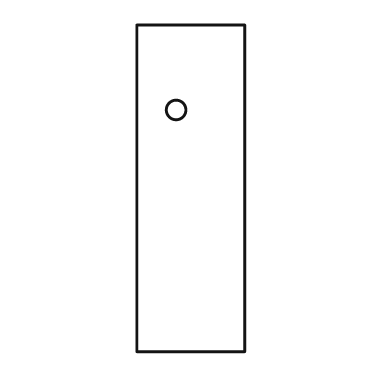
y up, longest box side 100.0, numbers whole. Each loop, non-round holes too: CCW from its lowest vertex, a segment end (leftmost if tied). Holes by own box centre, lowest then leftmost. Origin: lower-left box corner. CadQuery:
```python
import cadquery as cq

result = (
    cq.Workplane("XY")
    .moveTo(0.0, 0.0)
    .lineTo(33.0, 0.0)
    .lineTo(33.0, 100.0)
    .lineTo(0.0, 100.0)
    .close()
    .moveTo(12.0, 74.0)
    .circle(3.0)
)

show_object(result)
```